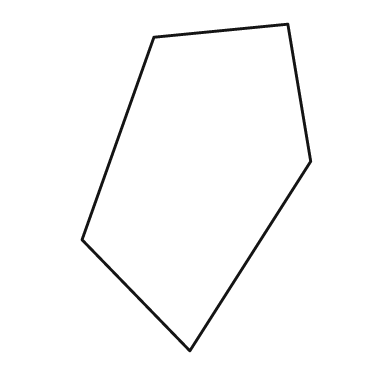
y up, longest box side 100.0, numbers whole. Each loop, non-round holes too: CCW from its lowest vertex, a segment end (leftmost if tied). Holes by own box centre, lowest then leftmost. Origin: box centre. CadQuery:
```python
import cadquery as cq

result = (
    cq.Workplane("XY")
    .moveTo(-2.0, -50.0)
    .lineTo(35.0, 8.0)
    .lineTo(28.0, 50.0)
    .lineTo(-13.0, 46.0)
    .lineTo(-35.0, -16.0)
    .close()
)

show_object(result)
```